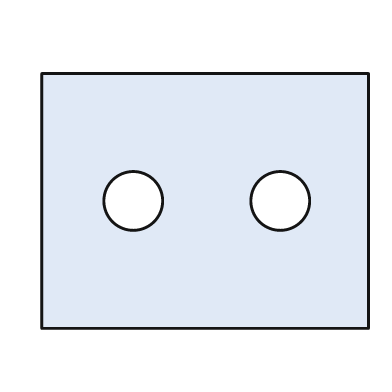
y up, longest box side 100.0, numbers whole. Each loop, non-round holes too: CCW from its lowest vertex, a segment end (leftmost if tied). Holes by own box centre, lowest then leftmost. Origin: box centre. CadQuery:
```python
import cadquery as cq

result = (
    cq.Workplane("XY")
    .moveTo(-50.0, -39.0)
    .lineTo(50.0, -39.0)
    .lineTo(50.0, 39.0)
    .lineTo(-50.0, 39.0)
    .close()
    .moveTo(-22.0, 0.0)
    .circle(9.0)
    .moveTo(23.0, 0.0)
    .circle(9.0)
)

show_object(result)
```